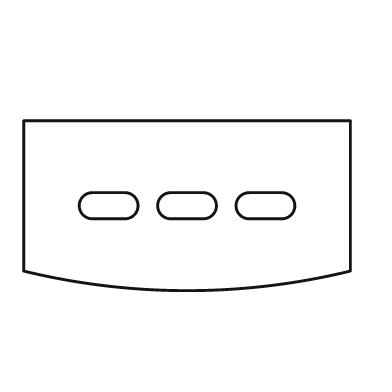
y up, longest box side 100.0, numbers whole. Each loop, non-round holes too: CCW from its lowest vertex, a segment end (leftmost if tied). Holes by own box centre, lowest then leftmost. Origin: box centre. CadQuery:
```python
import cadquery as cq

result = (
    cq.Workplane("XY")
    .moveTo(-50.0, -20.0)
    .threePointArc((0.0, -26.0), (50.0, -20.0))
    .lineTo(50.0, 26.0)
    .lineTo(-50.0, 26.0)
    .close()
    .moveTo(-29.0, -4.0)
    .lineTo(-19.0, -4.0)
    .threePointArc((-15.0, 0.0), (-19.0, 4.0))
    .lineTo(-29.0, 4.0)
    .threePointArc((-33.0, 0.0), (-29.0, -4.0))
    .close()
    .moveTo(-5.0, -4.0)
    .lineTo(5.0, -4.0)
    .threePointArc((9.0, 0.0), (5.0, 4.0))
    .lineTo(-5.0, 4.0)
    .threePointArc((-9.0, 0.0), (-5.0, -4.0))
    .close()
    .moveTo(19.0, -4.0)
    .lineTo(29.0, -4.0)
    .threePointArc((33.0, 0.0), (29.0, 4.0))
    .lineTo(19.0, 4.0)
    .threePointArc((15.0, 0.0), (19.0, -4.0))
    .close()
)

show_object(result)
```